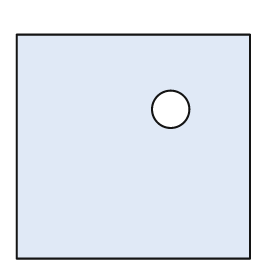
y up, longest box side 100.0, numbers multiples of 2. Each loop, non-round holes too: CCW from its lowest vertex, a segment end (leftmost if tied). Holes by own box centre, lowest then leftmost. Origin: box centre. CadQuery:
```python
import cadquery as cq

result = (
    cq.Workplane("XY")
    .moveTo(-50.0, -48.0)
    .lineTo(50.0, -48.0)
    .lineTo(50.0, 48.0)
    .lineTo(-50.0, 48.0)
    .close()
    .moveTo(16.0, 16.0)
    .circle(8.0)
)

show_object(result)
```